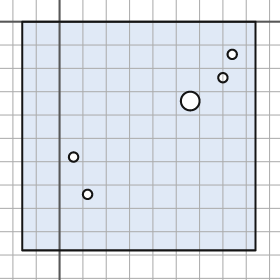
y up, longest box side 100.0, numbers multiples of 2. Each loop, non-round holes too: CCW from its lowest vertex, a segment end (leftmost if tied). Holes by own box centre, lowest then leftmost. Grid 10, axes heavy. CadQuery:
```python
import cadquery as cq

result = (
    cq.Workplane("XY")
    .moveTo(-16.0, -98.0)
    .lineTo(84.0, -98.0)
    .lineTo(84.0, 0.0)
    .lineTo(-16.0, 0.0)
    .close()
    .moveTo(12.0, -74.0)
    .circle(2.0)
    .moveTo(6.0, -58.0)
    .circle(2.0)
    .moveTo(56.0, -34.0)
    .circle(4.0)
    .moveTo(70.0, -24.0)
    .circle(2.0)
    .moveTo(74.0, -14.0)
    .circle(2.0)
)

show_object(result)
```